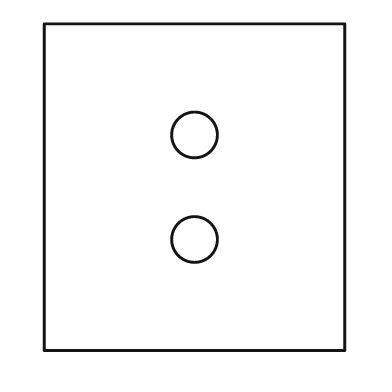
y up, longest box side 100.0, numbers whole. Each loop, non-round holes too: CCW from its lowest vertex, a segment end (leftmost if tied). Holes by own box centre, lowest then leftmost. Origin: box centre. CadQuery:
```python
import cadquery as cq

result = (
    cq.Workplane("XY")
    .moveTo(-46.0, -50.0)
    .lineTo(46.0, -50.0)
    .lineTo(46.0, 50.0)
    .lineTo(-46.0, 50.0)
    .close()
    .moveTo(0.0, -16.0)
    .circle(7.0)
    .moveTo(0.0, 16.0)
    .circle(7.0)
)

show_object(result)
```